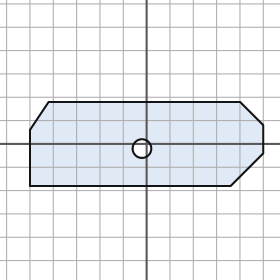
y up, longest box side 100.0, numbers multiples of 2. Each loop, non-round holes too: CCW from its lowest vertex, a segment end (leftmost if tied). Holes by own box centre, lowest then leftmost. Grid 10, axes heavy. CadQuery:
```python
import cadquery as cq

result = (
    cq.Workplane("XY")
    .moveTo(-50.0, -18.0)
    .lineTo(36.0, -18.0)
    .lineTo(50.0, -4.0)
    .lineTo(50.0, 8.0)
    .lineTo(40.0, 18.0)
    .lineTo(-42.0, 18.0)
    .lineTo(-50.0, 6.0)
    .close()
    .moveTo(-2.0, -2.0)
    .circle(4.0)
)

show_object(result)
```